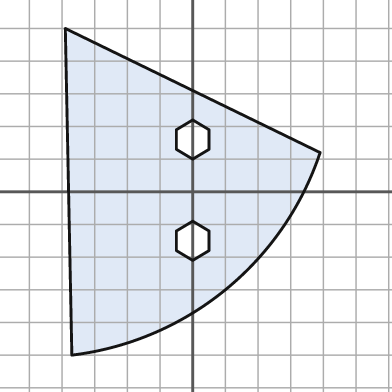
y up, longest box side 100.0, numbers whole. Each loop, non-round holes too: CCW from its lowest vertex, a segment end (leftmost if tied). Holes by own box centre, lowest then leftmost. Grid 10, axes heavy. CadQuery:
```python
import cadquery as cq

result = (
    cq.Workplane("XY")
    .moveTo(-37.0, -50.0)
    .threePointArc((10.0, -30.0), (39.0, 12.0))
    .lineTo(-39.0, 50.0)
    .close()
    .moveTo(0.0, -21.0)
    .lineTo(5.0, -18.0)
    .lineTo(5.0, -12.0)
    .lineTo(0.0, -9.0)
    .lineTo(-5.0, -12.0)
    .lineTo(-5.0, -18.0)
    .close()
    .moveTo(0.0, 10.0)
    .lineTo(5.0, 13.0)
    .lineTo(5.0, 19.0)
    .lineTo(0.0, 22.0)
    .lineTo(-5.0, 19.0)
    .lineTo(-5.0, 13.0)
    .close()
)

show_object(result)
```